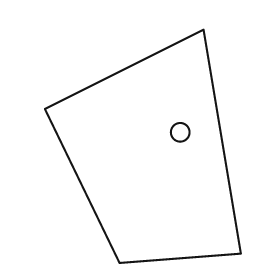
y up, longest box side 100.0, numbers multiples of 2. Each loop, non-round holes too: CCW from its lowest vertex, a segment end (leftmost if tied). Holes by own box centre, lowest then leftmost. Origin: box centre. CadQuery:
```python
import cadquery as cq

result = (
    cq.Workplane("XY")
    .moveTo(-10.0, -50.0)
    .lineTo(42.0, -46.0)
    .lineTo(26.0, 50.0)
    .lineTo(-42.0, 16.0)
    .close()
    .moveTo(16.0, 6.0)
    .circle(4.0)
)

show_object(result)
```